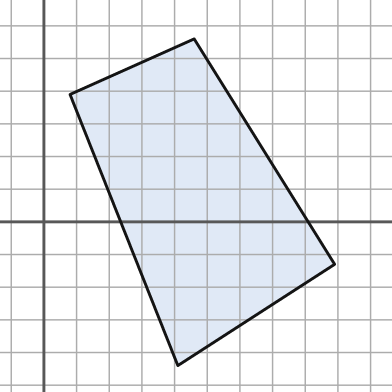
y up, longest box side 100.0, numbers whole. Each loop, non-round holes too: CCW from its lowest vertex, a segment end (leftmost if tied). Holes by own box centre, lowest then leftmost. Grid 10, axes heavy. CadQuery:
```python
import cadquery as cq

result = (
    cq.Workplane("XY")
    .moveTo(41.0, -44.0)
    .lineTo(89.0, -13.0)
    .lineTo(46.0, 56.0)
    .lineTo(8.0, 39.0)
    .close()
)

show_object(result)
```